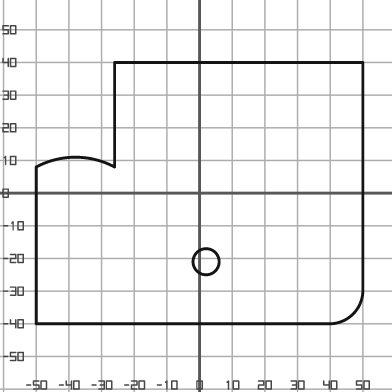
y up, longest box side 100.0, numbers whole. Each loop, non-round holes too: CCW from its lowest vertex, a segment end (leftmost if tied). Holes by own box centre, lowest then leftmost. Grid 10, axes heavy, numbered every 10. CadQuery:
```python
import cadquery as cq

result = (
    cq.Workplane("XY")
    .moveTo(-50.0, -40.0)
    .lineTo(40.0, -40.0)
    .threePointArc((47.0, -37.0), (50.0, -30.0))
    .lineTo(50.0, 40.0)
    .lineTo(-26.0, 40.0)
    .lineTo(-26.0, 8.0)
    .threePointArc((-38.0, 11.0), (-50.0, 8.0))
    .close()
    .moveTo(2.0, -21.0)
    .circle(4.0)
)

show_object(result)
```